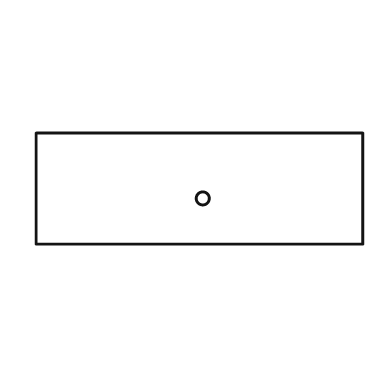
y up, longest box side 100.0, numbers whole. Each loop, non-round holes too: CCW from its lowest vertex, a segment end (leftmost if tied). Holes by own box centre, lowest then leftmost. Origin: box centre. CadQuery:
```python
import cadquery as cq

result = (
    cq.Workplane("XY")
    .moveTo(-50.0, -17.0)
    .lineTo(50.0, -17.0)
    .lineTo(50.0, 17.0)
    .lineTo(-50.0, 17.0)
    .close()
    .moveTo(1.0, -3.0)
    .circle(2.0)
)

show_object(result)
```